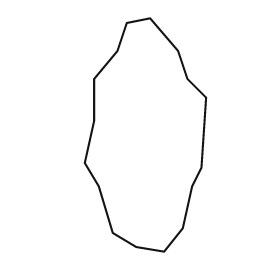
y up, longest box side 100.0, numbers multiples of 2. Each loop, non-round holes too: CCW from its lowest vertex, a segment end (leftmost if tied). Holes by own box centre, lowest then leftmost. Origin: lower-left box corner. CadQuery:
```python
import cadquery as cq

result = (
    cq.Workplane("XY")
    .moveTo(34.0, 0.0)
    .lineTo(42.0, 10.0)
    .lineTo(46.0, 28.0)
    .lineTo(50.0, 36.0)
    .lineTo(52.0, 66.0)
    .lineTo(44.0, 74.0)
    .lineTo(40.0, 86.0)
    .lineTo(28.0, 100.0)
    .lineTo(18.0, 98.0)
    .lineTo(14.0, 86.0)
    .lineTo(4.0, 74.0)
    .lineTo(4.0, 56.0)
    .lineTo(0.0, 38.0)
    .lineTo(6.0, 28.0)
    .lineTo(12.0, 8.0)
    .lineTo(22.0, 2.0)
    .close()
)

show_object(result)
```